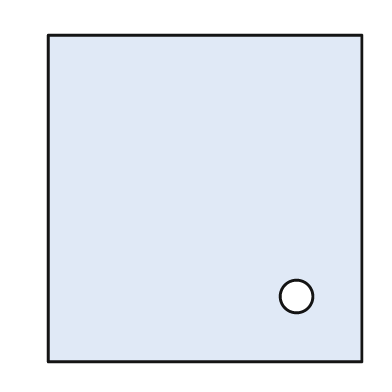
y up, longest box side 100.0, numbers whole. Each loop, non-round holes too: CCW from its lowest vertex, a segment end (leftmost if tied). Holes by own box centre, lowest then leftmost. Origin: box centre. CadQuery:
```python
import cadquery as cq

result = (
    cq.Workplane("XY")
    .moveTo(-48.0, -50.0)
    .lineTo(48.0, -50.0)
    .lineTo(48.0, 50.0)
    .lineTo(-48.0, 50.0)
    .close()
    .moveTo(28.0, -30.0)
    .circle(5.0)
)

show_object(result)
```